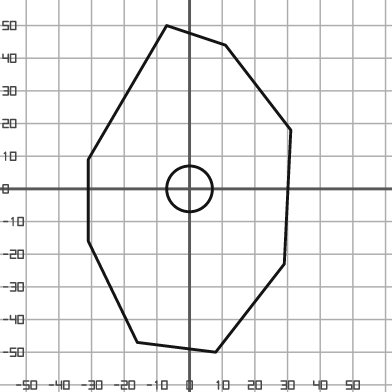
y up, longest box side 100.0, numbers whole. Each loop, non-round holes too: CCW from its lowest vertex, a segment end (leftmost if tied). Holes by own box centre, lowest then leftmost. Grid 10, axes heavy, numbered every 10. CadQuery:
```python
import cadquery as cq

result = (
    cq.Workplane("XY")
    .moveTo(8.0, -50.0)
    .lineTo(29.0, -23.0)
    .lineTo(31.0, 18.0)
    .lineTo(11.0, 44.0)
    .lineTo(-7.0, 50.0)
    .lineTo(-31.0, 9.0)
    .lineTo(-31.0, -16.0)
    .lineTo(-16.0, -47.0)
    .close()
    .moveTo(0.0, 0.0)
    .circle(7.0)
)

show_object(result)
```